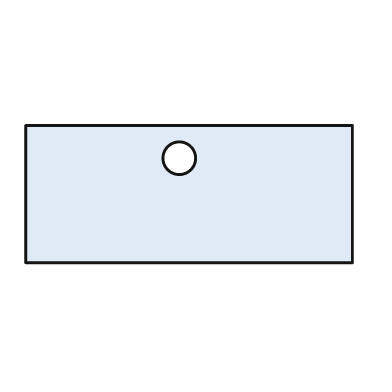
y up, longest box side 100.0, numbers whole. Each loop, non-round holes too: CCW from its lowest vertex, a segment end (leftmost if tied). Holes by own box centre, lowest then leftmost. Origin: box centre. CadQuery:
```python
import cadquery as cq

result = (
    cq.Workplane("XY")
    .moveTo(-50.0, -21.0)
    .lineTo(50.0, -21.0)
    .lineTo(50.0, 21.0)
    .lineTo(-50.0, 21.0)
    .close()
    .moveTo(-3.0, 11.0)
    .circle(5.0)
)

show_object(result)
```